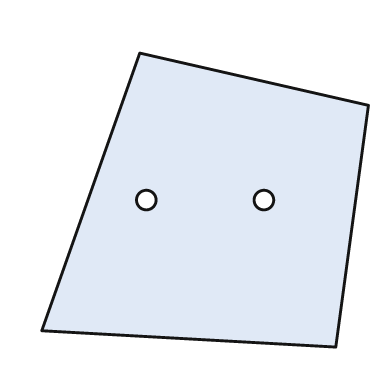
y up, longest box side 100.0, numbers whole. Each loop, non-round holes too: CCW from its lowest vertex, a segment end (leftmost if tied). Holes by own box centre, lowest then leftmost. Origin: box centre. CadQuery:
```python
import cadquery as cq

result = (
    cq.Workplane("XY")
    .moveTo(40.0, -45.0)
    .lineTo(50.0, 29.0)
    .lineTo(-20.0, 45.0)
    .lineTo(-50.0, -40.0)
    .close()
    .moveTo(-18.0, 0.0)
    .circle(3.0)
    .moveTo(18.0, 0.0)
    .circle(3.0)
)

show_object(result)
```